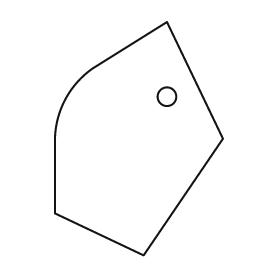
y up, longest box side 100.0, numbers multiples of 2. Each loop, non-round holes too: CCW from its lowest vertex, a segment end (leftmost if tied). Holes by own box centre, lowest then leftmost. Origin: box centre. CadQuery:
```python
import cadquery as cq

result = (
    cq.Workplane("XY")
    .moveTo(2.0, -50.0)
    .lineTo(36.0, 0.0)
    .lineTo(12.0, 50.0)
    .lineTo(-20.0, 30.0)
    .threePointArc((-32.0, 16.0), (-36.0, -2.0))
    .lineTo(-36.0, -32.0)
    .close()
    .moveTo(12.0, 18.0)
    .circle(4.0)
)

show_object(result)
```